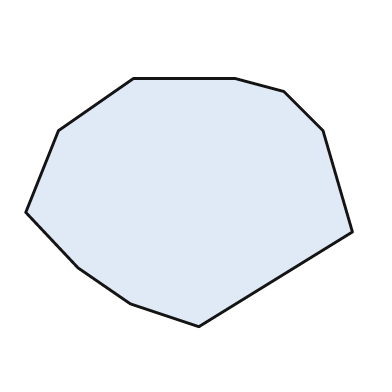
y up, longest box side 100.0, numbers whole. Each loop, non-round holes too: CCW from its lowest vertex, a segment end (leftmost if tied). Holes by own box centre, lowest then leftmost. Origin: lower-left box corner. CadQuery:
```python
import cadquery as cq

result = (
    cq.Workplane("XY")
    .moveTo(53.0, 0.0)
    .lineTo(100.0, 29.0)
    .lineTo(91.0, 60.0)
    .lineTo(79.0, 72.0)
    .lineTo(64.0, 76.0)
    .lineTo(33.0, 76.0)
    .lineTo(10.0, 60.0)
    .lineTo(0.0, 35.0)
    .lineTo(16.0, 18.0)
    .lineTo(32.0, 7.0)
    .close()
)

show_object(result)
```